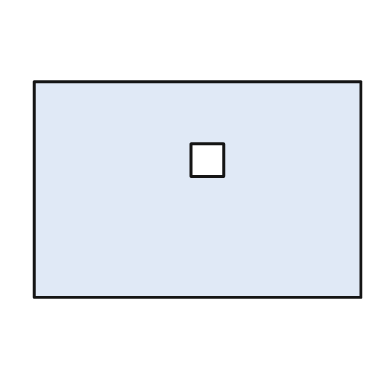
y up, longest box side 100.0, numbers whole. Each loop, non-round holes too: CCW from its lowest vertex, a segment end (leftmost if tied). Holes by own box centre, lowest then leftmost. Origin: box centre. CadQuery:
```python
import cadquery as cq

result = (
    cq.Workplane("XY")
    .moveTo(-50.0, -33.0)
    .lineTo(50.0, -33.0)
    .lineTo(50.0, 33.0)
    .lineTo(-50.0, 33.0)
    .close()
    .moveTo(-2.0, 4.0)
    .lineTo(8.0, 4.0)
    .lineTo(8.0, 14.0)
    .lineTo(-2.0, 14.0)
    .close()
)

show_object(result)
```